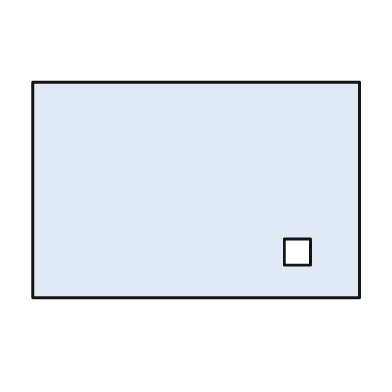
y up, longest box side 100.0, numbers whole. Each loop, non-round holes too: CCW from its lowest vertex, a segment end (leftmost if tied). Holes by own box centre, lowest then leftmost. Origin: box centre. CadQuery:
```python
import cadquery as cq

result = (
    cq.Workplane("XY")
    .moveTo(-50.0, -33.0)
    .lineTo(50.0, -33.0)
    .lineTo(50.0, 33.0)
    .lineTo(-50.0, 33.0)
    .close()
    .moveTo(27.0, -23.0)
    .lineTo(35.0, -23.0)
    .lineTo(35.0, -15.0)
    .lineTo(27.0, -15.0)
    .close()
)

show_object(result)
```